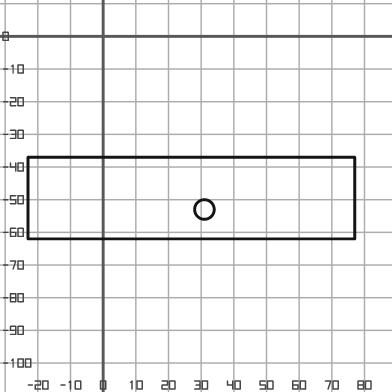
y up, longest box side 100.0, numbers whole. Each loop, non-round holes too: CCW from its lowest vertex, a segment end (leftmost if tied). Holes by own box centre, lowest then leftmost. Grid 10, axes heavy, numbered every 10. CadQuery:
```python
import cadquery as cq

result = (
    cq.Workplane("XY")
    .moveTo(-23.0, -62.0)
    .lineTo(77.0, -62.0)
    .lineTo(77.0, -37.0)
    .lineTo(-23.0, -37.0)
    .close()
    .moveTo(31.0, -53.0)
    .circle(3.0)
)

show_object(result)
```